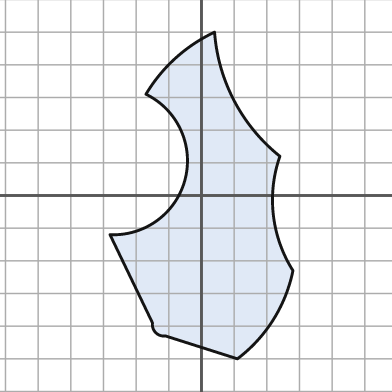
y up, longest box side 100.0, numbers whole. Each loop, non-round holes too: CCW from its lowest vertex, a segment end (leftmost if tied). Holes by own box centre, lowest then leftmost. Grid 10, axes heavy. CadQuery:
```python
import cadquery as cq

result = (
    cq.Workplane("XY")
    .moveTo(11.0, -50.0)
    .threePointArc((22.0, -38.0), (28.0, -23.0))
    .threePointArc((22.0, -6.0), (24.0, 12.0))
    .threePointArc((10.0, 29.0), (4.0, 50.0))
    .threePointArc((-8.0, 42.0), (-17.0, 31.0))
    .threePointArc((-5.0, 5.0), (-28.0, -12.0))
    .lineTo(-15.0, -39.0)
    .threePointArc((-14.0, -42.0), (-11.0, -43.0))
    .close()
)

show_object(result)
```